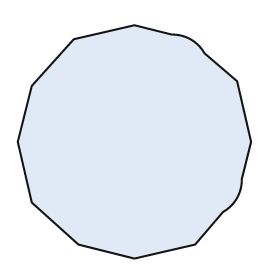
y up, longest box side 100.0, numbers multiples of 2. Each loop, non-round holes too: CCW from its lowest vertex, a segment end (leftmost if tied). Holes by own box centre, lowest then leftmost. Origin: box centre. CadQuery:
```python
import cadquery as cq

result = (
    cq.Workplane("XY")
    .moveTo(0.0, -50.0)
    .lineTo(26.0, -44.0)
    .lineTo(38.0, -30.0)
    .threePointArc((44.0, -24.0), (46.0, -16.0))
    .lineTo(50.0, 0.0)
    .lineTo(44.0, 26.0)
    .lineTo(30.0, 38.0)
    .threePointArc((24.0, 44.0), (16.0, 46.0))
    .lineTo(0.0, 50.0)
    .lineTo(-26.0, 44.0)
    .lineTo(-44.0, 24.0)
    .lineTo(-50.0, 0.0)
    .lineTo(-44.0, -26.0)
    .lineTo(-24.0, -44.0)
    .close()
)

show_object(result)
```